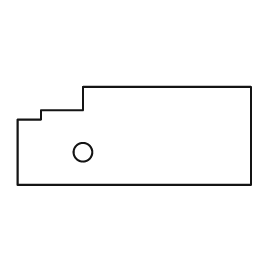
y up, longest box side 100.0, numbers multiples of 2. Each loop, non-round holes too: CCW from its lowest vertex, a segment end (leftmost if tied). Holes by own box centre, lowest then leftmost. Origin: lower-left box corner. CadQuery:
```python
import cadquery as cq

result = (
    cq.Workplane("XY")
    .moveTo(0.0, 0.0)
    .lineTo(100.0, 0.0)
    .lineTo(100.0, 42.0)
    .lineTo(28.0, 42.0)
    .lineTo(28.0, 32.0)
    .lineTo(10.0, 32.0)
    .lineTo(10.0, 28.0)
    .lineTo(0.0, 28.0)
    .close()
    .moveTo(28.0, 14.0)
    .circle(4.0)
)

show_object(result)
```